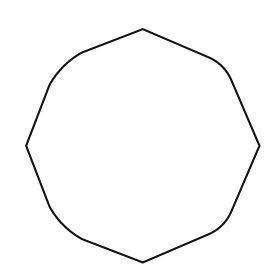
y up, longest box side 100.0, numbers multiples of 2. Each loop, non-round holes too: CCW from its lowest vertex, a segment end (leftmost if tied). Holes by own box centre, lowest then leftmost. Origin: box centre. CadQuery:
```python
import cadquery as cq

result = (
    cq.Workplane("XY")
    .moveTo(0.0, -50.0)
    .lineTo(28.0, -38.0)
    .threePointArc((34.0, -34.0), (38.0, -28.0))
    .lineTo(50.0, 0.0)
    .lineTo(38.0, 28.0)
    .threePointArc((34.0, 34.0), (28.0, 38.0))
    .lineTo(0.0, 50.0)
    .lineTo(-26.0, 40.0)
    .threePointArc((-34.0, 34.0), (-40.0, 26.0))
    .lineTo(-50.0, 0.0)
    .lineTo(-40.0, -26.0)
    .threePointArc((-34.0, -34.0), (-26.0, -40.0))
    .close()
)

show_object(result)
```